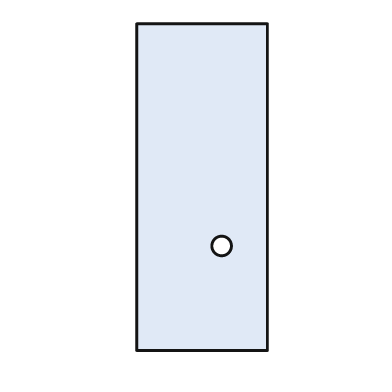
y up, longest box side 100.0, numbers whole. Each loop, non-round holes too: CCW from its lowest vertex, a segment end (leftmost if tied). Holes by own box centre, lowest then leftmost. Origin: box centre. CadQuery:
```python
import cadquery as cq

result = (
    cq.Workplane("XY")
    .moveTo(-20.0, -50.0)
    .lineTo(20.0, -50.0)
    .lineTo(20.0, 50.0)
    .lineTo(-20.0, 50.0)
    .close()
    .moveTo(6.0, -18.0)
    .circle(3.0)
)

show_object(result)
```